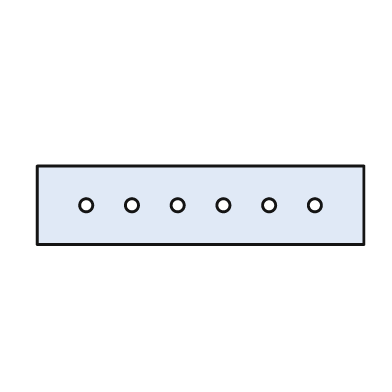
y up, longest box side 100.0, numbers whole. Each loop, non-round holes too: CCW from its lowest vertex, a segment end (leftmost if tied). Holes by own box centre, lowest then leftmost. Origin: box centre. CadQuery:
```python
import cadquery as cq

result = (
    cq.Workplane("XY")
    .moveTo(-50.0, -12.0)
    .lineTo(50.0, -12.0)
    .lineTo(50.0, 12.0)
    .lineTo(-50.0, 12.0)
    .close()
    .moveTo(-35.0, 0.0)
    .circle(2.0)
    .moveTo(-21.0, 0.0)
    .circle(2.0)
    .moveTo(-7.0, 0.0)
    .circle(2.0)
    .moveTo(7.0, 0.0)
    .circle(2.0)
    .moveTo(21.0, 0.0)
    .circle(2.0)
    .moveTo(35.0, 0.0)
    .circle(2.0)
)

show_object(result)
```